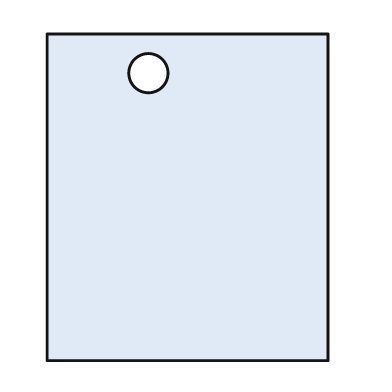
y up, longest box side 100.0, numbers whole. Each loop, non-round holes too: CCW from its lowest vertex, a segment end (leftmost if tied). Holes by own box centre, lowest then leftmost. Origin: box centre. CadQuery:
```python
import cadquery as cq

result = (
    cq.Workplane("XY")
    .moveTo(-43.0, -50.0)
    .lineTo(43.0, -50.0)
    .lineTo(43.0, 50.0)
    .lineTo(-43.0, 50.0)
    .close()
    .moveTo(-12.0, 38.0)
    .circle(6.0)
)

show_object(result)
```